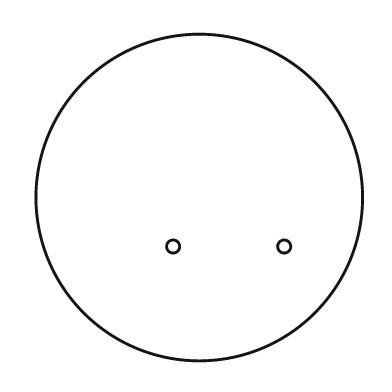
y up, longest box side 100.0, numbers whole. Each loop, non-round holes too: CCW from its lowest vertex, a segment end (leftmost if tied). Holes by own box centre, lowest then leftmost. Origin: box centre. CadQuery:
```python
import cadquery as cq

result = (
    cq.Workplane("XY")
    .moveTo(0.0, 0.0)
    .circle(50.0)
    .moveTo(-8.0, -15.0)
    .circle(2.0)
    .moveTo(26.0, -15.0)
    .circle(2.0)
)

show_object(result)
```